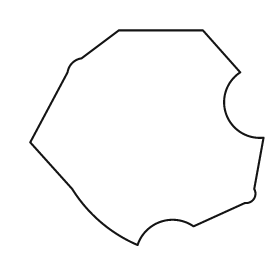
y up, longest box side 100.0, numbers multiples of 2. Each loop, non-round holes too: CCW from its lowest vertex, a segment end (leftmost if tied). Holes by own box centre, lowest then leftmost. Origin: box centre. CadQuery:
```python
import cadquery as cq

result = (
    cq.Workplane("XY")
    .moveTo(-4.0, -46.0)
    .threePointArc((6.0, -36.0), (20.0, -38.0))
    .lineTo(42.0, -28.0)
    .threePointArc((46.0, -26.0), (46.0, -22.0))
    .lineTo(50.0, 0.0)
    .threePointArc((34.0, 10.0), (40.0, 28.0))
    .lineTo(24.0, 46.0)
    .lineTo(-12.0, 46.0)
    .lineTo(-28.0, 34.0)
    .threePointArc((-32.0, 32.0), (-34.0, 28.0))
    .lineTo(-50.0, -2.0)
    .lineTo(-32.0, -22.0)
    .threePointArc((-20.0, -36.0), (-4.0, -46.0))
    .close()
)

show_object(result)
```